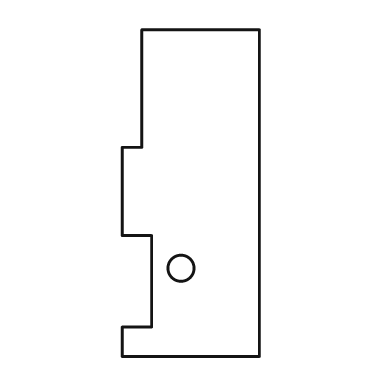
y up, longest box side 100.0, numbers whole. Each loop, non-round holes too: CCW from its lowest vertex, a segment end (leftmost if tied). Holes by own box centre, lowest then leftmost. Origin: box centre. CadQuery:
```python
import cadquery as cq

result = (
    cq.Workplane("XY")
    .moveTo(-21.0, -50.0)
    .lineTo(21.0, -50.0)
    .lineTo(21.0, 50.0)
    .lineTo(-15.0, 50.0)
    .lineTo(-15.0, 14.0)
    .lineTo(-21.0, 14.0)
    .lineTo(-21.0, -13.0)
    .lineTo(-12.0, -13.0)
    .lineTo(-12.0, -41.0)
    .lineTo(-21.0, -41.0)
    .close()
    .moveTo(-3.0, -23.0)
    .circle(4.0)
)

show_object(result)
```